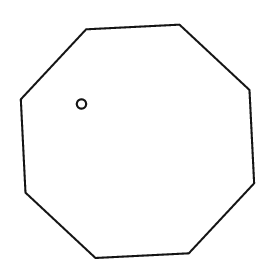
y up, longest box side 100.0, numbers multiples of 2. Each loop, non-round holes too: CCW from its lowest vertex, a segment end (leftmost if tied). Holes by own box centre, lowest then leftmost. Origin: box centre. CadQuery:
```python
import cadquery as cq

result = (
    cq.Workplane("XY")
    .moveTo(-18.0, -50.0)
    .lineTo(22.0, -48.0)
    .lineTo(50.0, -18.0)
    .lineTo(48.0, 22.0)
    .lineTo(18.0, 50.0)
    .lineTo(-22.0, 48.0)
    .lineTo(-50.0, 18.0)
    .lineTo(-48.0, -22.0)
    .close()
    .moveTo(-24.0, 16.0)
    .circle(2.0)
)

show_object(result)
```